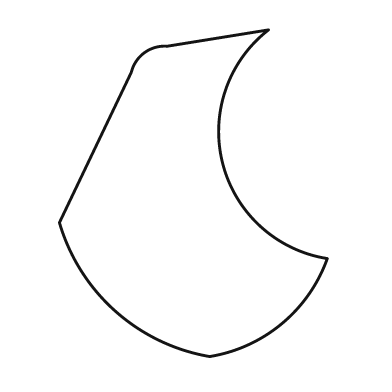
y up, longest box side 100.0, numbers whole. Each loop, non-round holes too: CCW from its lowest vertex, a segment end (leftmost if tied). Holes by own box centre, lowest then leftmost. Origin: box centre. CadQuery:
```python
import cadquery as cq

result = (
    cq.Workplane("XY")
    .moveTo(5.0, -50.0)
    .threePointArc((27.0, -40.0), (41.0, -20.0))
    .threePointArc((9.0, 9.0), (23.0, 50.0))
    .lineTo(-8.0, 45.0)
    .threePointArc((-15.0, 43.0), (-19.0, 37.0))
    .lineTo(-41.0, -9.0)
    .threePointArc((-24.0, -36.0), (5.0, -50.0))
    .close()
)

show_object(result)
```